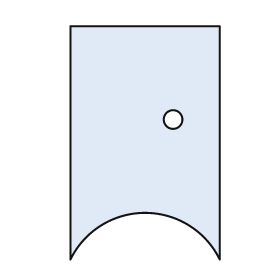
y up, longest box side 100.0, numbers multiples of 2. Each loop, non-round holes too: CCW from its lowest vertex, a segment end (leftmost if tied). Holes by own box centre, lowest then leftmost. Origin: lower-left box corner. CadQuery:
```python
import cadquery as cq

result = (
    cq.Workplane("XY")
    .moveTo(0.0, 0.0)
    .threePointArc((32.0, 20.0), (64.0, 0.0))
    .lineTo(64.0, 100.0)
    .lineTo(0.0, 100.0)
    .close()
    .moveTo(44.0, 60.0)
    .circle(4.0)
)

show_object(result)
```